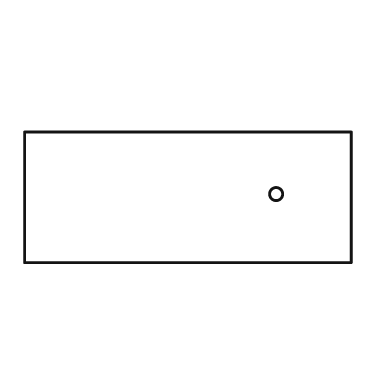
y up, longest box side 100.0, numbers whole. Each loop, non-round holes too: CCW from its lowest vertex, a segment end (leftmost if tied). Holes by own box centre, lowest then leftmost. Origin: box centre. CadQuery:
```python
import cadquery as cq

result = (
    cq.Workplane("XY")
    .moveTo(-50.0, -20.0)
    .lineTo(50.0, -20.0)
    .lineTo(50.0, 20.0)
    .lineTo(-50.0, 20.0)
    .close()
    .moveTo(27.0, 1.0)
    .circle(2.0)
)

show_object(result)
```